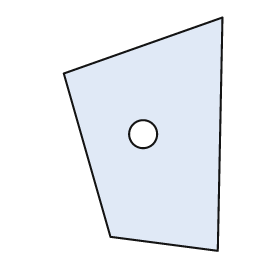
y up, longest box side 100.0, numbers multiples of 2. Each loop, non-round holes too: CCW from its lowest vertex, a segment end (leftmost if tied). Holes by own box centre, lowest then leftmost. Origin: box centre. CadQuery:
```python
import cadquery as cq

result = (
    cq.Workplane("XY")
    .moveTo(32.0, -50.0)
    .lineTo(34.0, 50.0)
    .lineTo(-34.0, 26.0)
    .lineTo(-14.0, -44.0)
    .close()
    .moveTo(0.0, 0.0)
    .circle(6.0)
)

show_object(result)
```